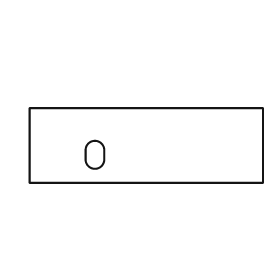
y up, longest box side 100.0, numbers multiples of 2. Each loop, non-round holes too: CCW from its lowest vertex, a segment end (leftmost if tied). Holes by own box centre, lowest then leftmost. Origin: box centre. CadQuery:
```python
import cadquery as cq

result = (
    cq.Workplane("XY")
    .moveTo(-50.0, -16.0)
    .lineTo(50.0, -16.0)
    .lineTo(50.0, 16.0)
    .lineTo(-50.0, 16.0)
    .close()
    .moveTo(-26.0, -6.0)
    .threePointArc((-22.0, -10.0), (-18.0, -6.0))
    .lineTo(-18.0, -2.0)
    .threePointArc((-22.0, 2.0), (-26.0, -2.0))
    .close()
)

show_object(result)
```